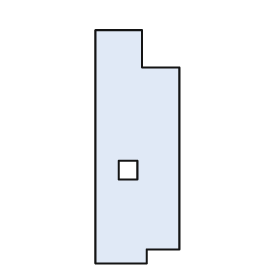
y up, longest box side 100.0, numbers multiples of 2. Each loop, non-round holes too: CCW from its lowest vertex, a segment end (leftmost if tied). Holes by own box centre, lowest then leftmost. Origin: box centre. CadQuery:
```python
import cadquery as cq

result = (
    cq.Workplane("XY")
    .moveTo(-18.0, -50.0)
    .lineTo(4.0, -50.0)
    .lineTo(4.0, -44.0)
    .lineTo(18.0, -44.0)
    .lineTo(18.0, 34.0)
    .lineTo(2.0, 34.0)
    .lineTo(2.0, 50.0)
    .lineTo(-18.0, 50.0)
    .close()
    .moveTo(-8.0, -14.0)
    .lineTo(0.0, -14.0)
    .lineTo(0.0, -6.0)
    .lineTo(-8.0, -6.0)
    .close()
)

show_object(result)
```